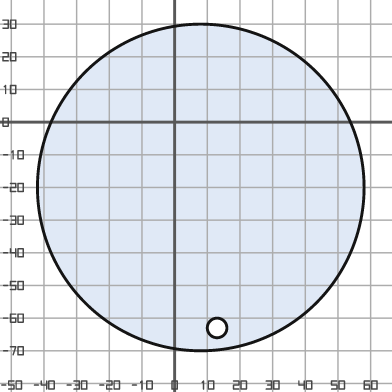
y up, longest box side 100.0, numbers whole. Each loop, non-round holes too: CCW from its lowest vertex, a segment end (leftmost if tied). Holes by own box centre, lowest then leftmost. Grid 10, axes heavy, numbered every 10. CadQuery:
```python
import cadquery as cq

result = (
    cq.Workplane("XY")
    .moveTo(8.0, -20.0)
    .circle(50.0)
    .moveTo(13.0, -63.0)
    .circle(3.0)
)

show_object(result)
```